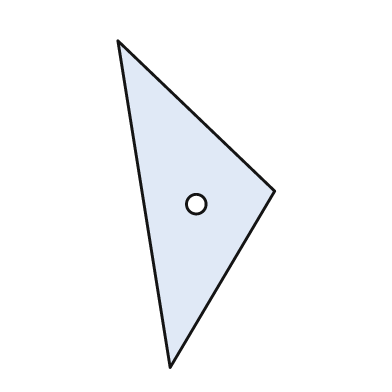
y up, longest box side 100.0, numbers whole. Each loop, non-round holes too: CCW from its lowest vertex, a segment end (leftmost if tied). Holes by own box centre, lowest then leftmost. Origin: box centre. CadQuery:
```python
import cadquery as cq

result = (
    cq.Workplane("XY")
    .moveTo(-8.0, -50.0)
    .lineTo(24.0, 4.0)
    .lineTo(-24.0, 50.0)
    .close()
    .moveTo(0.0, 0.0)
    .circle(3.0)
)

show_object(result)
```